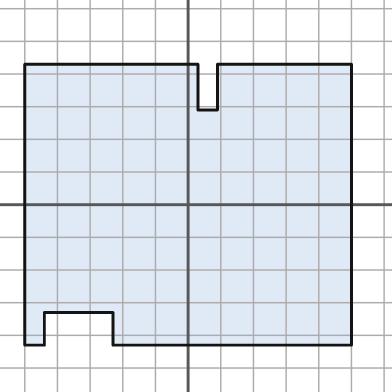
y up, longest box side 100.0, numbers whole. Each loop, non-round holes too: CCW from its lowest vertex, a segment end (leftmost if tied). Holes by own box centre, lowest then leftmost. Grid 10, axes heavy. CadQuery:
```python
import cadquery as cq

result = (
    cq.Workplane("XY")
    .moveTo(-50.0, -43.0)
    .lineTo(-44.0, -43.0)
    .lineTo(-44.0, -33.0)
    .lineTo(-23.0, -33.0)
    .lineTo(-23.0, -43.0)
    .lineTo(50.0, -43.0)
    .lineTo(50.0, 43.0)
    .lineTo(9.0, 43.0)
    .lineTo(9.0, 29.0)
    .lineTo(3.0, 29.0)
    .lineTo(3.0, 43.0)
    .lineTo(-50.0, 43.0)
    .close()
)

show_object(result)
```